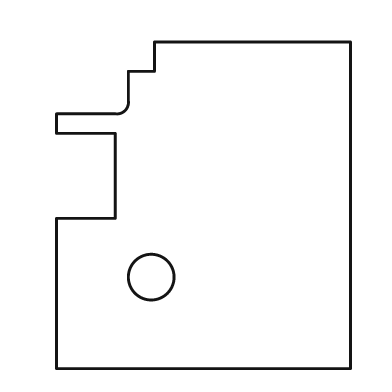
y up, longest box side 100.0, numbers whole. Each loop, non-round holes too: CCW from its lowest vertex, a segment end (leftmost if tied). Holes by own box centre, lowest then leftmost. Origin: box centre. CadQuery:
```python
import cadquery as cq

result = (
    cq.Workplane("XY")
    .moveTo(-45.0, -50.0)
    .lineTo(45.0, -50.0)
    .lineTo(45.0, 50.0)
    .lineTo(-15.0, 50.0)
    .lineTo(-15.0, 41.0)
    .lineTo(-23.0, 41.0)
    .lineTo(-23.0, 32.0)
    .threePointArc((-24.0, 29.0), (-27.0, 28.0))
    .lineTo(-45.0, 28.0)
    .lineTo(-45.0, 22.0)
    .lineTo(-27.0, 22.0)
    .lineTo(-27.0, -4.0)
    .lineTo(-45.0, -4.0)
    .close()
    .moveTo(-16.0, -22.0)
    .circle(7.0)
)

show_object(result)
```